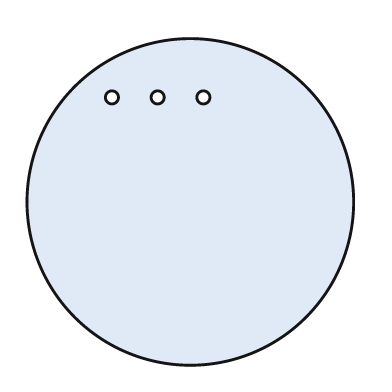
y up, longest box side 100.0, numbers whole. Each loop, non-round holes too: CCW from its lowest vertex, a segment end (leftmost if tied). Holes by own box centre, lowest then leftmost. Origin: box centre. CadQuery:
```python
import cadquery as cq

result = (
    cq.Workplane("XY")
    .moveTo(0.0, 0.0)
    .circle(50.0)
    .moveTo(-24.0, 32.0)
    .circle(2.0)
    .moveTo(-10.0, 32.0)
    .circle(2.0)
    .moveTo(4.0, 32.0)
    .circle(2.0)
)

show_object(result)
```